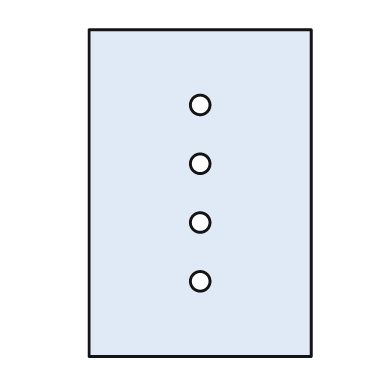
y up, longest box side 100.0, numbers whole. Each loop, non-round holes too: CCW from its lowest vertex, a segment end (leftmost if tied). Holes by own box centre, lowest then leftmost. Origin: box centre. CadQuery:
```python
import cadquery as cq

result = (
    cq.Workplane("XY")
    .moveTo(-34.0, -50.0)
    .lineTo(34.0, -50.0)
    .lineTo(34.0, 50.0)
    .lineTo(-34.0, 50.0)
    .close()
    .moveTo(0.0, -27.0)
    .circle(3.0)
    .moveTo(0.0, -9.0)
    .circle(3.0)
    .moveTo(0.0, 9.0)
    .circle(3.0)
    .moveTo(0.0, 27.0)
    .circle(3.0)
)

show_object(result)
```